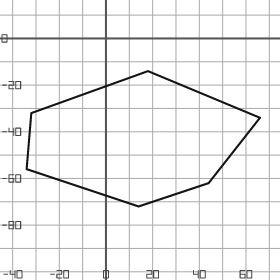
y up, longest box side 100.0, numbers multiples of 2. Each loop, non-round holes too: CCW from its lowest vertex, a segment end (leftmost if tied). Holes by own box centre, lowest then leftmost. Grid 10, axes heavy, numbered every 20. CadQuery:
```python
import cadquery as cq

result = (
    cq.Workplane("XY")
    .moveTo(14.0, -72.0)
    .lineTo(44.0, -62.0)
    .lineTo(66.0, -34.0)
    .lineTo(18.0, -14.0)
    .lineTo(-32.0, -32.0)
    .lineTo(-34.0, -56.0)
    .close()
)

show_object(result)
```